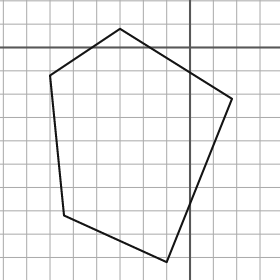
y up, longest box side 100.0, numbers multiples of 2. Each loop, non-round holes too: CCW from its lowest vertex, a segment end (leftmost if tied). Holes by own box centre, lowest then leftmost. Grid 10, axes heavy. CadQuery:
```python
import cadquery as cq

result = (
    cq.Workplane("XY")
    .moveTo(-10.0, -92.0)
    .lineTo(18.0, -22.0)
    .lineTo(-30.0, 8.0)
    .lineTo(-60.0, -12.0)
    .lineTo(-54.0, -72.0)
    .close()
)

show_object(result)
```